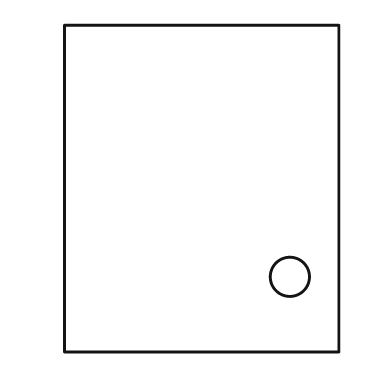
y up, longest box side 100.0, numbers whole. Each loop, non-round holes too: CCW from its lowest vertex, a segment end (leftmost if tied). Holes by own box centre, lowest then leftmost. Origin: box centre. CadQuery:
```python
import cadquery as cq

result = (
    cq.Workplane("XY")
    .moveTo(-42.0, -50.0)
    .lineTo(42.0, -50.0)
    .lineTo(42.0, 50.0)
    .lineTo(-42.0, 50.0)
    .close()
    .moveTo(27.0, -27.0)
    .circle(6.0)
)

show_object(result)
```